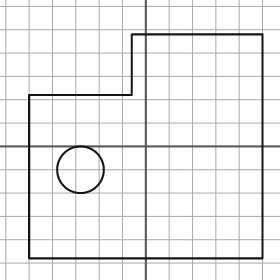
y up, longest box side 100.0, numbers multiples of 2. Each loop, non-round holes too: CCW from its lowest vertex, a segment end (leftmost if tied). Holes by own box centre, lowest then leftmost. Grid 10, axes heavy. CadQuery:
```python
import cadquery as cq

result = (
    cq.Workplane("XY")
    .moveTo(-50.0, -48.0)
    .lineTo(50.0, -48.0)
    .lineTo(50.0, 48.0)
    .lineTo(-6.0, 48.0)
    .lineTo(-6.0, 22.0)
    .lineTo(-50.0, 22.0)
    .close()
    .moveTo(-28.0, -10.0)
    .circle(10.0)
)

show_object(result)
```